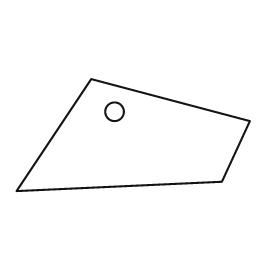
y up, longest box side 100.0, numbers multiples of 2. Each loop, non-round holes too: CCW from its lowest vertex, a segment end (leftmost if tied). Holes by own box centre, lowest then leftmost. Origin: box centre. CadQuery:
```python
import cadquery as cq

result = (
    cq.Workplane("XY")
    .moveTo(-50.0, -24.0)
    .lineTo(38.0, -20.0)
    .lineTo(50.0, 6.0)
    .lineTo(-18.0, 24.0)
    .close()
    .moveTo(-8.0, 10.0)
    .circle(4.0)
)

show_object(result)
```